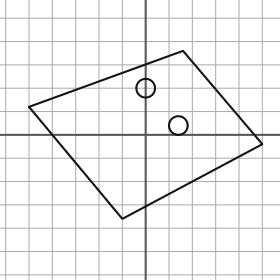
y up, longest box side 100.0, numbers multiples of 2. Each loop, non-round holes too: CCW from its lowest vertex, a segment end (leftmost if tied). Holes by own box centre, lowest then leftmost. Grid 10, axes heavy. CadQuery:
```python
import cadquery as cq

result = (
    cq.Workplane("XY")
    .moveTo(-10.0, -36.0)
    .lineTo(50.0, -4.0)
    .lineTo(16.0, 36.0)
    .lineTo(-50.0, 12.0)
    .close()
    .moveTo(14.0, 4.0)
    .circle(4.0)
    .moveTo(0.0, 20.0)
    .circle(4.0)
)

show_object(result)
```